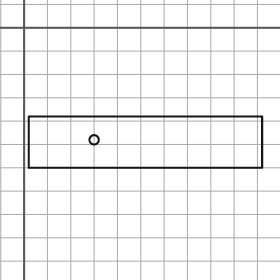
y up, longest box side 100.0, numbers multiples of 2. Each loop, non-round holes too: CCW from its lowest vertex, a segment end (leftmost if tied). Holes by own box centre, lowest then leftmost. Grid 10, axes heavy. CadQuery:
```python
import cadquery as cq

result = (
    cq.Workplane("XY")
    .moveTo(2.0, -60.0)
    .lineTo(102.0, -60.0)
    .lineTo(102.0, -38.0)
    .lineTo(2.0, -38.0)
    .close()
    .moveTo(30.0, -48.0)
    .circle(2.0)
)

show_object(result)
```